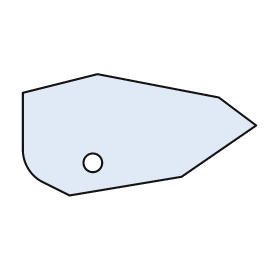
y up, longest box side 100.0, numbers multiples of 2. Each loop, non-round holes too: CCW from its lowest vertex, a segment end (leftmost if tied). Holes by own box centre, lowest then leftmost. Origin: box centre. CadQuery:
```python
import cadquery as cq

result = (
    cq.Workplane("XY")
    .moveTo(-30.0, -26.0)
    .lineTo(18.0, -18.0)
    .lineTo(50.0, 4.0)
    .lineTo(34.0, 16.0)
    .lineTo(-18.0, 26.0)
    .lineTo(-50.0, 18.0)
    .lineTo(-50.0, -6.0)
    .threePointArc((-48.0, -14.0), (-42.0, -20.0))
    .close()
    .moveTo(-20.0, -12.0)
    .circle(4.0)
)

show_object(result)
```